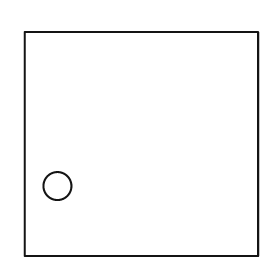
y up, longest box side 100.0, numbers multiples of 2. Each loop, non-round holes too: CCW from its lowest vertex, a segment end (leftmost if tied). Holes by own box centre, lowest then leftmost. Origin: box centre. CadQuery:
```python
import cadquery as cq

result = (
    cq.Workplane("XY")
    .moveTo(-50.0, -48.0)
    .lineTo(50.0, -48.0)
    .lineTo(50.0, 48.0)
    .lineTo(-50.0, 48.0)
    .close()
    .moveTo(-36.0, -18.0)
    .circle(6.0)
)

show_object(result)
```